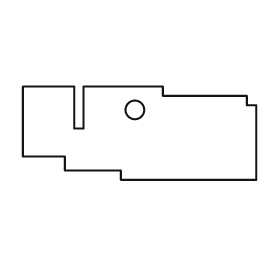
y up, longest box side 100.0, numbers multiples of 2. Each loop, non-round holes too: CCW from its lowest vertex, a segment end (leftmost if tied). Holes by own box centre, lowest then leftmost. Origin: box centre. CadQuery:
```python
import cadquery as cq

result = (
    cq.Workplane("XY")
    .moveTo(-8.0, -20.0)
    .lineTo(50.0, -20.0)
    .lineTo(50.0, 12.0)
    .lineTo(46.0, 12.0)
    .lineTo(46.0, 16.0)
    .lineTo(10.0, 16.0)
    .lineTo(10.0, 20.0)
    .lineTo(-24.0, 20.0)
    .lineTo(-24.0, 2.0)
    .lineTo(-28.0, 2.0)
    .lineTo(-28.0, 20.0)
    .lineTo(-50.0, 20.0)
    .lineTo(-50.0, -10.0)
    .lineTo(-32.0, -10.0)
    .lineTo(-32.0, -16.0)
    .lineTo(-8.0, -16.0)
    .close()
    .moveTo(-2.0, 10.0)
    .circle(4.0)
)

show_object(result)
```